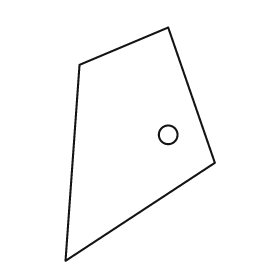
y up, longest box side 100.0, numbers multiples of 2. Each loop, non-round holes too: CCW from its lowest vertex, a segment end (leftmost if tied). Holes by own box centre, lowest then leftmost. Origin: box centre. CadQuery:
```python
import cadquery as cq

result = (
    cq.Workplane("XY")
    .moveTo(-32.0, -50.0)
    .lineTo(32.0, -8.0)
    .lineTo(12.0, 50.0)
    .lineTo(-26.0, 34.0)
    .close()
    .moveTo(12.0, 4.0)
    .circle(4.0)
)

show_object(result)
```